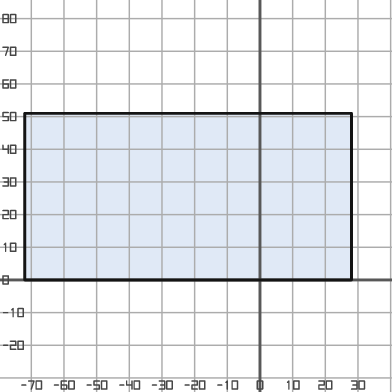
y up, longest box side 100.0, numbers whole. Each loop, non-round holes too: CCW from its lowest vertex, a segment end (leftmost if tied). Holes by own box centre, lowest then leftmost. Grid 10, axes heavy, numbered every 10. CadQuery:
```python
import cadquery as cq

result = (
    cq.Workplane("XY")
    .moveTo(-72.0, 0.0)
    .lineTo(28.0, 0.0)
    .lineTo(28.0, 51.0)
    .lineTo(-72.0, 51.0)
    .close()
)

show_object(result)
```